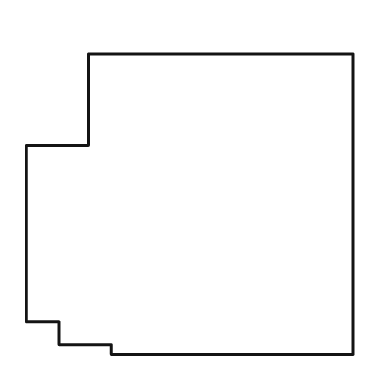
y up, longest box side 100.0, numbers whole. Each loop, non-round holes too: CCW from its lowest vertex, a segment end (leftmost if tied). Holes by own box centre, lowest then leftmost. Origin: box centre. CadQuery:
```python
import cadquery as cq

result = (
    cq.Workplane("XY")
    .moveTo(-24.0, -46.0)
    .lineTo(50.0, -46.0)
    .lineTo(50.0, 46.0)
    .lineTo(-31.0, 46.0)
    .lineTo(-31.0, 18.0)
    .lineTo(-50.0, 18.0)
    .lineTo(-50.0, -36.0)
    .lineTo(-40.0, -36.0)
    .lineTo(-40.0, -43.0)
    .lineTo(-24.0, -43.0)
    .close()
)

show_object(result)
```